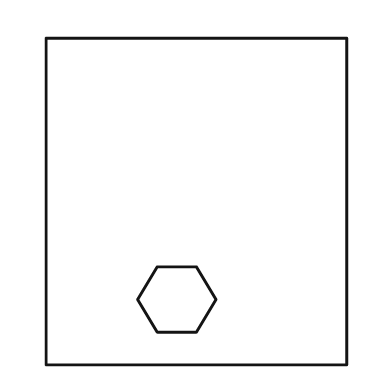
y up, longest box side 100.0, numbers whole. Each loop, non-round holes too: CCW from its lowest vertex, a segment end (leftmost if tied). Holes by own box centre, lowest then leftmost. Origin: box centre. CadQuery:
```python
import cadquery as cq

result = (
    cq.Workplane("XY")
    .moveTo(-46.0, -50.0)
    .lineTo(46.0, -50.0)
    .lineTo(46.0, 50.0)
    .lineTo(-46.0, 50.0)
    .close()
    .moveTo(-12.0, -40.0)
    .lineTo(0.0, -40.0)
    .lineTo(6.0, -30.0)
    .lineTo(0.0, -20.0)
    .lineTo(-12.0, -20.0)
    .lineTo(-18.0, -30.0)
    .close()
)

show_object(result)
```